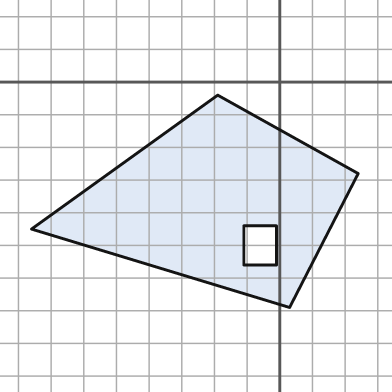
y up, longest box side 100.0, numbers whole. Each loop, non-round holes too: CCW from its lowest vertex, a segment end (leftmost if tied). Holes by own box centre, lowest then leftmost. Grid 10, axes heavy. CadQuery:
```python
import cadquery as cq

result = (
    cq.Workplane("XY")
    .moveTo(3.0, -69.0)
    .lineTo(24.0, -28.0)
    .lineTo(-19.0, -4.0)
    .lineTo(-76.0, -45.0)
    .close()
    .moveTo(-11.0, -56.0)
    .lineTo(-1.0, -56.0)
    .lineTo(-1.0, -44.0)
    .lineTo(-11.0, -44.0)
    .close()
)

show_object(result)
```